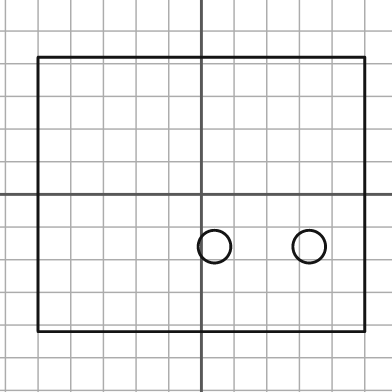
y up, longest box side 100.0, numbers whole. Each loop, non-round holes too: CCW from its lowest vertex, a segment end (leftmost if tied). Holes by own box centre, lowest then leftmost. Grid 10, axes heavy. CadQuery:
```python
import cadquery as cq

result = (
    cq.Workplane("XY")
    .moveTo(-50.0, -42.0)
    .lineTo(50.0, -42.0)
    .lineTo(50.0, 42.0)
    .lineTo(-50.0, 42.0)
    .close()
    .moveTo(4.0, -16.0)
    .circle(5.0)
    .moveTo(33.0, -16.0)
    .circle(5.0)
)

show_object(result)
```